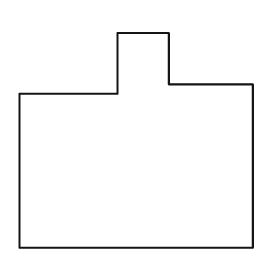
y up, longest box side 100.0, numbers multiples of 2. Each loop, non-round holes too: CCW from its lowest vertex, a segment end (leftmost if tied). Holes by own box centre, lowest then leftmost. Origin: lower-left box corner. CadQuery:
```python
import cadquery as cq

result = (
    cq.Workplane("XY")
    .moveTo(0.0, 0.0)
    .lineTo(100.0, 0.0)
    .lineTo(100.0, 70.0)
    .lineTo(64.0, 70.0)
    .lineTo(64.0, 92.0)
    .lineTo(42.0, 92.0)
    .lineTo(42.0, 66.0)
    .lineTo(0.0, 66.0)
    .close()
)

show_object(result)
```